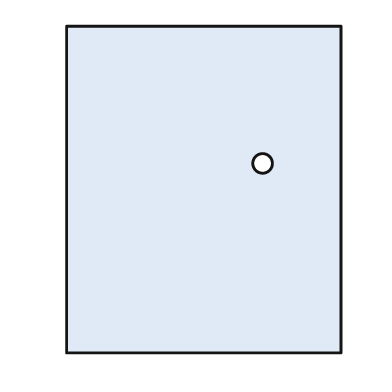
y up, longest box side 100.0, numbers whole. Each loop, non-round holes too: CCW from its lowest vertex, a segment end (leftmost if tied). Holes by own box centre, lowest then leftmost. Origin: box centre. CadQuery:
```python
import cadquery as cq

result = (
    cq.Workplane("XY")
    .moveTo(-42.0, -50.0)
    .lineTo(42.0, -50.0)
    .lineTo(42.0, 50.0)
    .lineTo(-42.0, 50.0)
    .close()
    .moveTo(18.0, 8.0)
    .circle(3.0)
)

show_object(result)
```